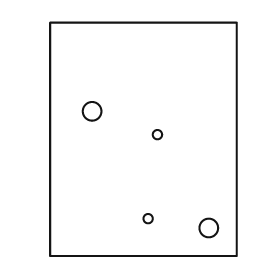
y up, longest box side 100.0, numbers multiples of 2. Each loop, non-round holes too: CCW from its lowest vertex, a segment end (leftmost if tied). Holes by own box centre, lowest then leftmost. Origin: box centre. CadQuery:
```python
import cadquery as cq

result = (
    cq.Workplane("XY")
    .moveTo(-40.0, -50.0)
    .lineTo(40.0, -50.0)
    .lineTo(40.0, 50.0)
    .lineTo(-40.0, 50.0)
    .close()
    .moveTo(28.0, -38.0)
    .circle(4.0)
    .moveTo(2.0, -34.0)
    .circle(2.0)
    .moveTo(6.0, 2.0)
    .circle(2.0)
    .moveTo(-22.0, 12.0)
    .circle(4.0)
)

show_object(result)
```